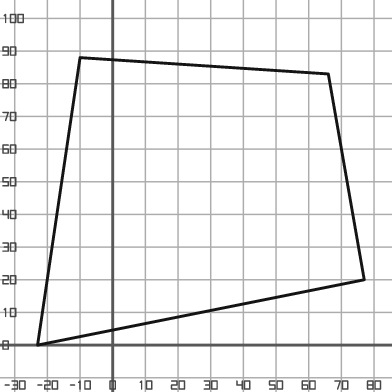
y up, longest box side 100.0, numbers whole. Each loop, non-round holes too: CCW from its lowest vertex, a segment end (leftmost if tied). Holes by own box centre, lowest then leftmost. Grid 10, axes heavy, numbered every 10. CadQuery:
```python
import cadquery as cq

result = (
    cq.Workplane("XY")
    .moveTo(-23.0, 0.0)
    .lineTo(77.0, 20.0)
    .lineTo(66.0, 83.0)
    .lineTo(-10.0, 88.0)
    .close()
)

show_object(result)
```